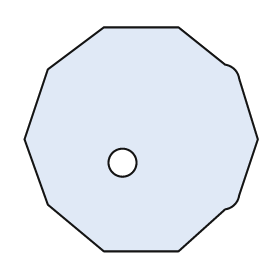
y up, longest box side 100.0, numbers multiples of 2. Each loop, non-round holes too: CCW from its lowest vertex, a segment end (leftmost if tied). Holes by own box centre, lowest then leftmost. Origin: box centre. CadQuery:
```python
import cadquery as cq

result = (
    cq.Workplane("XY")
    .moveTo(-16.0, -48.0)
    .lineTo(16.0, -48.0)
    .lineTo(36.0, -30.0)
    .threePointArc((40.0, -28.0), (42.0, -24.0))
    .lineTo(50.0, 0.0)
    .lineTo(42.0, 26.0)
    .threePointArc((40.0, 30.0), (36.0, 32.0))
    .lineTo(16.0, 48.0)
    .lineTo(-16.0, 48.0)
    .lineTo(-40.0, 30.0)
    .lineTo(-50.0, 0.0)
    .lineTo(-40.0, -28.0)
    .close()
    .moveTo(-8.0, -10.0)
    .circle(6.0)
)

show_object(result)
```